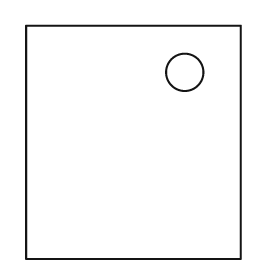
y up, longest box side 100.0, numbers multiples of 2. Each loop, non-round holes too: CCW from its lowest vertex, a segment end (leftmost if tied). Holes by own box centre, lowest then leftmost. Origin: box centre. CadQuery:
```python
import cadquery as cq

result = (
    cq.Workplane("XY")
    .moveTo(-46.0, -50.0)
    .lineTo(46.0, -50.0)
    .lineTo(46.0, 50.0)
    .lineTo(-46.0, 50.0)
    .close()
    .moveTo(22.0, 30.0)
    .circle(8.0)
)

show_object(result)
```